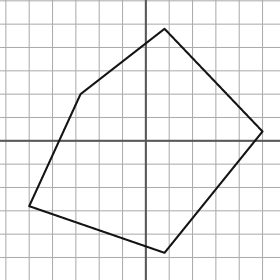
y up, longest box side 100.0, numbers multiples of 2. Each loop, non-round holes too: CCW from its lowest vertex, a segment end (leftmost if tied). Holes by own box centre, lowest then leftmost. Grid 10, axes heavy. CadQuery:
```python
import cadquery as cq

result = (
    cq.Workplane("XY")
    .moveTo(8.0, -48.0)
    .lineTo(50.0, 4.0)
    .lineTo(8.0, 48.0)
    .lineTo(-28.0, 20.0)
    .lineTo(-50.0, -28.0)
    .close()
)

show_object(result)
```